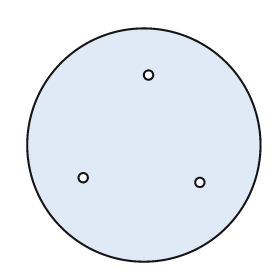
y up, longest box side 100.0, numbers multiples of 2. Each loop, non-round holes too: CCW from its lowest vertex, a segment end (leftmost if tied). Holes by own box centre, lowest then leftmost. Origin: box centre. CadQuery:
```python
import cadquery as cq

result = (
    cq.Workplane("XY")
    .moveTo(0.0, 0.0)
    .circle(50.0)
    .moveTo(24.0, -16.0)
    .circle(2.0)
    .moveTo(-26.0, -14.0)
    .circle(2.0)
    .moveTo(2.0, 30.0)
    .circle(2.0)
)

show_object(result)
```